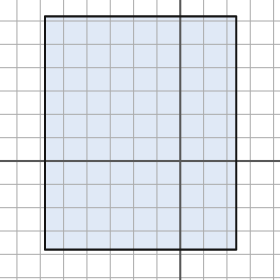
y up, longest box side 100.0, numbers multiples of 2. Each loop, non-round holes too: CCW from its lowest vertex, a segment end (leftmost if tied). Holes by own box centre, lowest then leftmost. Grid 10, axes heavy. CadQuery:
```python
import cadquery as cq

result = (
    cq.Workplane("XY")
    .moveTo(-58.0, -38.0)
    .lineTo(24.0, -38.0)
    .lineTo(24.0, 62.0)
    .lineTo(-58.0, 62.0)
    .close()
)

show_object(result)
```